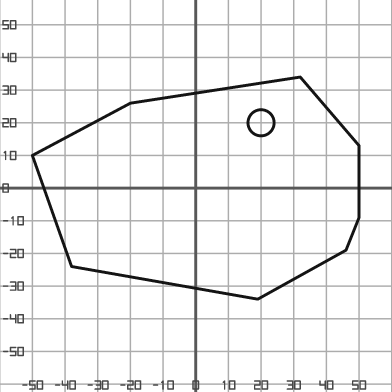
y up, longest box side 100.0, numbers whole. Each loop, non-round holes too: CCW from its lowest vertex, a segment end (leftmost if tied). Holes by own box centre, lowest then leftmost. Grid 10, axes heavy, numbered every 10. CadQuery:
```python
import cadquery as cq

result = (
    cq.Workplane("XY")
    .moveTo(19.0, -34.0)
    .lineTo(46.0, -19.0)
    .lineTo(50.0, -9.0)
    .lineTo(50.0, 13.0)
    .lineTo(32.0, 34.0)
    .lineTo(-20.0, 26.0)
    .lineTo(-50.0, 10.0)
    .lineTo(-38.0, -24.0)
    .close()
    .moveTo(20.0, 20.0)
    .circle(4.0)
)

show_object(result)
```